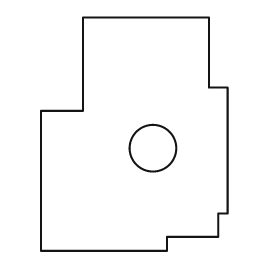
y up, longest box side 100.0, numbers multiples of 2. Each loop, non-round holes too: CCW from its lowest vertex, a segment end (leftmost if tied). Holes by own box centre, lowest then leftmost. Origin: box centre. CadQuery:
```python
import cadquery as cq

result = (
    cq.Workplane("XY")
    .moveTo(-40.0, -50.0)
    .lineTo(14.0, -50.0)
    .lineTo(14.0, -44.0)
    .lineTo(36.0, -44.0)
    .lineTo(36.0, -34.0)
    .lineTo(40.0, -34.0)
    .lineTo(40.0, 20.0)
    .lineTo(32.0, 20.0)
    .lineTo(32.0, 50.0)
    .lineTo(-22.0, 50.0)
    .lineTo(-22.0, 10.0)
    .lineTo(-40.0, 10.0)
    .close()
    .moveTo(8.0, -6.0)
    .circle(10.0)
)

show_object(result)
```